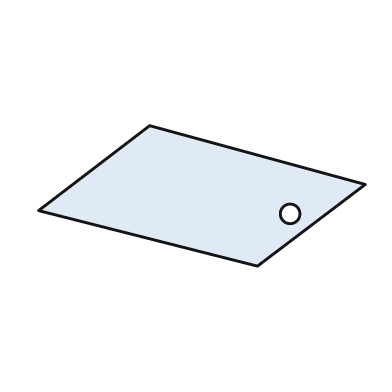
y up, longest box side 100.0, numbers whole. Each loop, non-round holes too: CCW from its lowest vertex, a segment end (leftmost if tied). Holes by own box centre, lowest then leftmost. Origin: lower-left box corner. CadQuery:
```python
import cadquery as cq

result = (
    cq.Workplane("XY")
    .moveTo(67.0, 0.0)
    .lineTo(100.0, 25.0)
    .lineTo(34.0, 43.0)
    .lineTo(0.0, 17.0)
    .close()
    .moveTo(77.0, 16.0)
    .circle(3.0)
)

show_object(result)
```